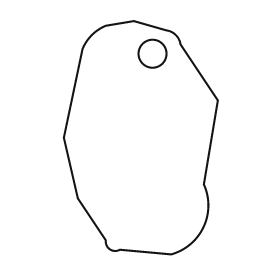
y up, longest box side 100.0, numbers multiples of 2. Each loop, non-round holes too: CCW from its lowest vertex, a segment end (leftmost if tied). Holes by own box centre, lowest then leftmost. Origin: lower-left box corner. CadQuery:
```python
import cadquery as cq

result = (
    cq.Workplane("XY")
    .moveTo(46.0, 0.0)
    .threePointArc((60.0, 12.0), (60.0, 30.0))
    .lineTo(66.0, 66.0)
    .lineTo(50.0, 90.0)
    .threePointArc((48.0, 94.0), (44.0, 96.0))
    .lineTo(30.0, 100.0)
    .lineTo(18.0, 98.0)
    .threePointArc((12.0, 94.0), (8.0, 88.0))
    .lineTo(0.0, 50.0)
    .lineTo(6.0, 24.0)
    .lineTo(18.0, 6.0)
    .threePointArc((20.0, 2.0), (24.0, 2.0))
    .close()
    .moveTo(38.0, 86.0)
    .circle(6.0)
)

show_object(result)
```